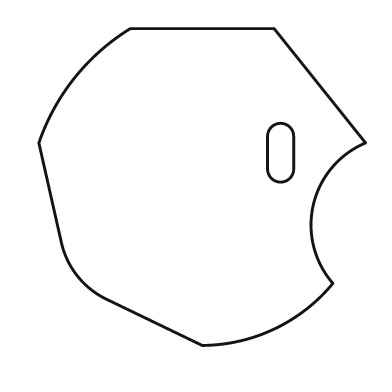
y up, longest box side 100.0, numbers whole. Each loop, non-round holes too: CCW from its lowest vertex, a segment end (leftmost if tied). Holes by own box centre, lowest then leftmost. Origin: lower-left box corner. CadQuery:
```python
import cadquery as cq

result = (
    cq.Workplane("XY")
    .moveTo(50.0, 0.0)
    .threePointArc((72.0, 5.0), (90.0, 19.0))
    .threePointArc((84.0, 43.0), (100.0, 62.0))
    .lineTo(72.0, 97.0)
    .lineTo(28.0, 97.0)
    .threePointArc((11.0, 82.0), (0.0, 62.0))
    .lineTo(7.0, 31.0)
    .threePointArc((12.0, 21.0), (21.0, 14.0))
    .close()
    .moveTo(70.0, 54.0)
    .threePointArc((74.0, 50.0), (78.0, 54.0))
    .lineTo(78.0, 64.0)
    .threePointArc((74.0, 68.0), (70.0, 64.0))
    .close()
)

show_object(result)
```